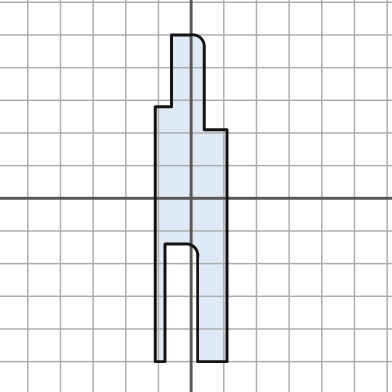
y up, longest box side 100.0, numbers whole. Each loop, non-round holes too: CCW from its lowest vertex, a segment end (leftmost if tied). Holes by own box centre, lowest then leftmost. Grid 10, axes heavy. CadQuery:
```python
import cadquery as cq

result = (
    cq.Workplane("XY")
    .moveTo(-11.0, -50.0)
    .lineTo(-8.0, -50.0)
    .lineTo(-8.0, -14.0)
    .lineTo(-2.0, -14.0)
    .threePointArc((1.0, -15.0), (2.0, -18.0))
    .lineTo(2.0, -50.0)
    .lineTo(11.0, -50.0)
    .lineTo(11.0, 21.0)
    .lineTo(4.0, 21.0)
    .lineTo(4.0, 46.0)
    .threePointArc((3.0, 49.0), (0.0, 50.0))
    .lineTo(-6.0, 50.0)
    .lineTo(-6.0, 28.0)
    .lineTo(-11.0, 28.0)
    .close()
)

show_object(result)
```